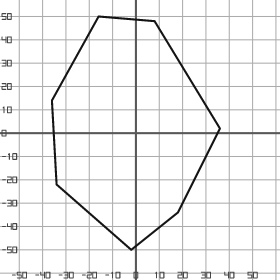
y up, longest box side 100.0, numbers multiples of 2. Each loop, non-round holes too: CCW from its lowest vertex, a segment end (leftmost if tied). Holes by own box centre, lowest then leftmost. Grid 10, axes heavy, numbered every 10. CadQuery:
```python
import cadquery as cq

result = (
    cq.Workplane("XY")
    .moveTo(-2.0, -50.0)
    .lineTo(18.0, -34.0)
    .lineTo(36.0, 2.0)
    .lineTo(8.0, 48.0)
    .lineTo(-16.0, 50.0)
    .lineTo(-36.0, 14.0)
    .lineTo(-34.0, -22.0)
    .close()
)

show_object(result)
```